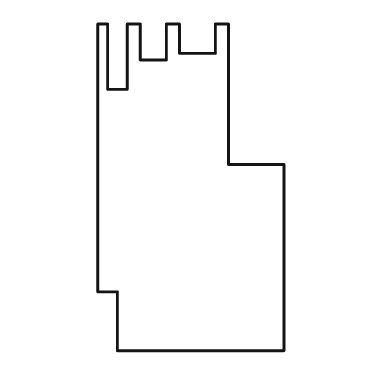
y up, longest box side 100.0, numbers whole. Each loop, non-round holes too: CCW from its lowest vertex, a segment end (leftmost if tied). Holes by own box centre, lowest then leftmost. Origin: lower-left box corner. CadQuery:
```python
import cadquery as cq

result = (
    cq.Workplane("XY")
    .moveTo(6.0, 0.0)
    .lineTo(57.0, 0.0)
    .lineTo(57.0, 57.0)
    .lineTo(40.0, 57.0)
    .lineTo(40.0, 100.0)
    .lineTo(36.0, 100.0)
    .lineTo(36.0, 91.0)
    .lineTo(25.0, 91.0)
    .lineTo(25.0, 100.0)
    .lineTo(21.0, 100.0)
    .lineTo(21.0, 89.0)
    .lineTo(13.0, 89.0)
    .lineTo(13.0, 100.0)
    .lineTo(9.0, 100.0)
    .lineTo(9.0, 80.0)
    .lineTo(3.0, 80.0)
    .lineTo(3.0, 100.0)
    .lineTo(0.0, 100.0)
    .lineTo(0.0, 18.0)
    .lineTo(6.0, 18.0)
    .close()
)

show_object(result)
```